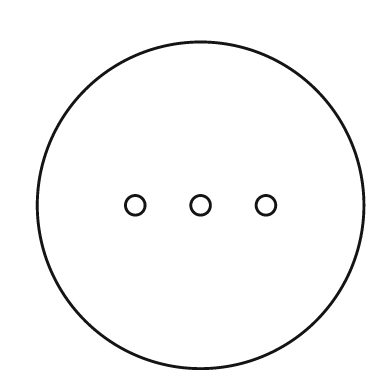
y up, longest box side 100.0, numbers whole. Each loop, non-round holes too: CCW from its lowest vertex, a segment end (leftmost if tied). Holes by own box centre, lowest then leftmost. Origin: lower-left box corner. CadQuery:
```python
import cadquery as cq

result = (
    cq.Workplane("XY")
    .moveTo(50.0, 50.0)
    .circle(50.0)
    .moveTo(30.0, 50.0)
    .circle(3.0)
    .moveTo(50.0, 50.0)
    .circle(3.0)
    .moveTo(70.0, 50.0)
    .circle(3.0)
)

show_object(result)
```